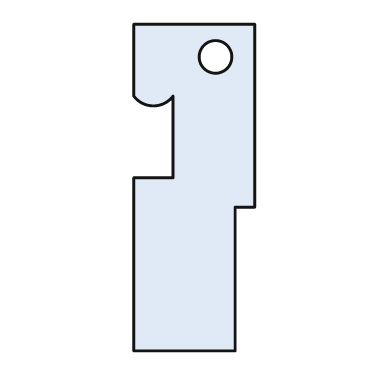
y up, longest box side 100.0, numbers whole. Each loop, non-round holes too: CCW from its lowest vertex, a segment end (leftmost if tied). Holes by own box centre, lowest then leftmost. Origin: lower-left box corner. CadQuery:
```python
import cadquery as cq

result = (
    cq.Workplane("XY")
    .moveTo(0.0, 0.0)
    .lineTo(31.0, 0.0)
    .lineTo(31.0, 44.0)
    .lineTo(37.0, 44.0)
    .lineTo(37.0, 100.0)
    .lineTo(0.0, 100.0)
    .lineTo(0.0, 78.0)
    .threePointArc((6.0, 75.0), (12.0, 78.0))
    .lineTo(12.0, 53.0)
    .lineTo(0.0, 53.0)
    .close()
    .moveTo(25.0, 90.0)
    .circle(5.0)
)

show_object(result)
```